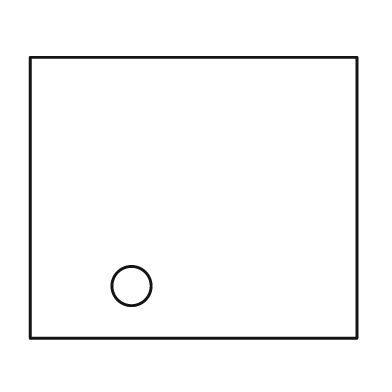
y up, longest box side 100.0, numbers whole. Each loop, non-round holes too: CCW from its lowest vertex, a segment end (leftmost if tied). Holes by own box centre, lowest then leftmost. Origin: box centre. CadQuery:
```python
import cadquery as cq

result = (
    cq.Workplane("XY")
    .moveTo(-50.0, -43.0)
    .lineTo(50.0, -43.0)
    .lineTo(50.0, 43.0)
    .lineTo(-50.0, 43.0)
    .close()
    .moveTo(-19.0, -27.0)
    .circle(6.0)
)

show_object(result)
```